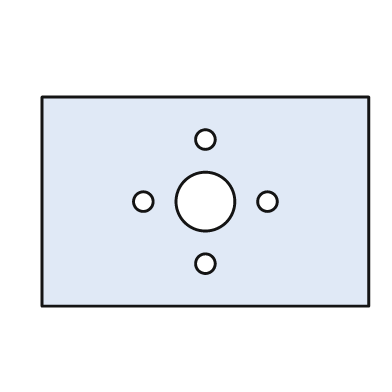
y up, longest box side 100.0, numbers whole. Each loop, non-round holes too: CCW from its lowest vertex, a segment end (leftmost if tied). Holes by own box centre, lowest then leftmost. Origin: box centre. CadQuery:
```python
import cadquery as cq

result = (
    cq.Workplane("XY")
    .moveTo(-50.0, -32.0)
    .lineTo(50.0, -32.0)
    .lineTo(50.0, 32.0)
    .lineTo(-50.0, 32.0)
    .close()
    .moveTo(0.0, -19.0)
    .circle(3.0)
    .moveTo(-19.0, 0.0)
    .circle(3.0)
    .moveTo(0.0, 0.0)
    .circle(9.0)
    .moveTo(19.0, 0.0)
    .circle(3.0)
    .moveTo(0.0, 19.0)
    .circle(3.0)
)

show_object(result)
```